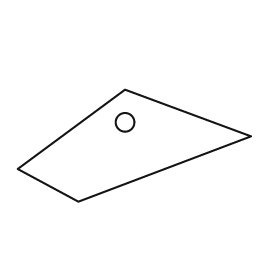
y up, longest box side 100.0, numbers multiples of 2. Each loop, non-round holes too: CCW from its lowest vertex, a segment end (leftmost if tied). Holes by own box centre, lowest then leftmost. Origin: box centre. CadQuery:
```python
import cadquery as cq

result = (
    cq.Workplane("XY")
    .moveTo(-24.0, -24.0)
    .lineTo(50.0, 4.0)
    .lineTo(-4.0, 24.0)
    .lineTo(-50.0, -10.0)
    .close()
    .moveTo(-4.0, 10.0)
    .circle(4.0)
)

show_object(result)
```